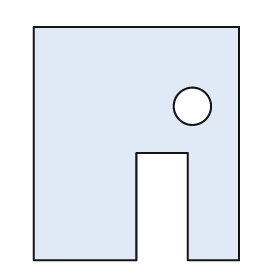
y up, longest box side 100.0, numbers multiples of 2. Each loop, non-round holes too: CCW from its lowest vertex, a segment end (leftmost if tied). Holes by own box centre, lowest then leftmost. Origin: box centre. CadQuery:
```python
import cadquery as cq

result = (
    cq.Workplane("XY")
    .moveTo(-44.0, -50.0)
    .lineTo(0.0, -50.0)
    .lineTo(0.0, -4.0)
    .lineTo(22.0, -4.0)
    .lineTo(22.0, -50.0)
    .lineTo(44.0, -50.0)
    .lineTo(44.0, 50.0)
    .lineTo(-44.0, 50.0)
    .close()
    .moveTo(24.0, 16.0)
    .circle(8.0)
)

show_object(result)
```